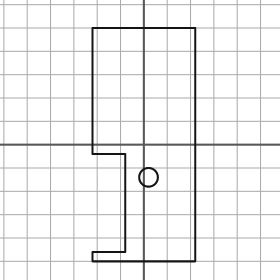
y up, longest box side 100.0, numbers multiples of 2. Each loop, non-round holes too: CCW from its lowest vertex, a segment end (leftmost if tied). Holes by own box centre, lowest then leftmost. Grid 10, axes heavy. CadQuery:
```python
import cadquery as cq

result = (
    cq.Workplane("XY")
    .moveTo(-22.0, -50.0)
    .lineTo(22.0, -50.0)
    .lineTo(22.0, 50.0)
    .lineTo(-22.0, 50.0)
    .lineTo(-22.0, -4.0)
    .lineTo(-8.0, -4.0)
    .lineTo(-8.0, -46.0)
    .lineTo(-22.0, -46.0)
    .close()
    .moveTo(2.0, -14.0)
    .circle(4.0)
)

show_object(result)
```